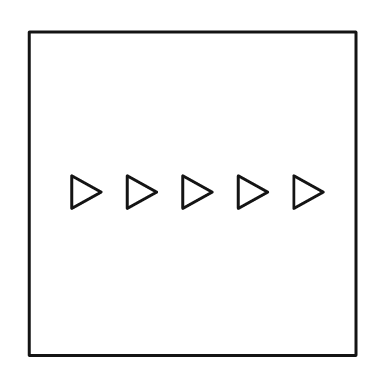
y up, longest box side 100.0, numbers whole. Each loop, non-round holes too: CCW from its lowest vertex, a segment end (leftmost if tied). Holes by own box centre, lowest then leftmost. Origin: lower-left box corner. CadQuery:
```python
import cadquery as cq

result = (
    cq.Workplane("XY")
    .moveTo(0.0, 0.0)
    .lineTo(100.0, 0.0)
    .lineTo(100.0, 99.0)
    .lineTo(0.0, 99.0)
    .close()
    .moveTo(13.0, 45.0)
    .lineTo(22.0, 50.0)
    .lineTo(13.0, 55.0)
    .close()
    .moveTo(30.0, 45.0)
    .lineTo(39.0, 50.0)
    .lineTo(30.0, 55.0)
    .close()
    .moveTo(47.0, 45.0)
    .lineTo(56.0, 50.0)
    .lineTo(47.0, 55.0)
    .close()
    .moveTo(64.0, 45.0)
    .lineTo(73.0, 50.0)
    .lineTo(64.0, 55.0)
    .close()
    .moveTo(81.0, 45.0)
    .lineTo(90.0, 50.0)
    .lineTo(81.0, 55.0)
    .close()
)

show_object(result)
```